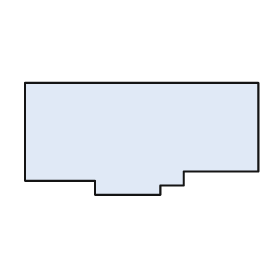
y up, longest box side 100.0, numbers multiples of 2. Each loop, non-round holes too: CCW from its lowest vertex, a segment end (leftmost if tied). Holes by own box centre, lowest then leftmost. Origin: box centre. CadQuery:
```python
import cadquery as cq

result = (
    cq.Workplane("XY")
    .moveTo(-20.0, -24.0)
    .lineTo(8.0, -24.0)
    .lineTo(8.0, -20.0)
    .lineTo(18.0, -20.0)
    .lineTo(18.0, -14.0)
    .lineTo(50.0, -14.0)
    .lineTo(50.0, 24.0)
    .lineTo(-50.0, 24.0)
    .lineTo(-50.0, -18.0)
    .lineTo(-20.0, -18.0)
    .close()
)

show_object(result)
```